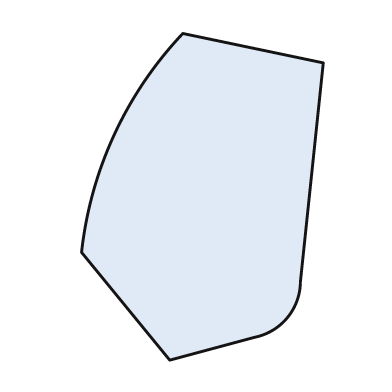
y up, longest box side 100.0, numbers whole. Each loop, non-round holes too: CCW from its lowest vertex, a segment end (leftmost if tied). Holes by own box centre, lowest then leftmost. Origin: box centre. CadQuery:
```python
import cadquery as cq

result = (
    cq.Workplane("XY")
    .moveTo(-10.0, -50.0)
    .lineTo(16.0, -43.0)
    .threePointArc((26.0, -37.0), (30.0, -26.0))
    .lineTo(37.0, 41.0)
    .lineTo(-6.0, 50.0)
    .threePointArc((-27.0, 19.0), (-37.0, -17.0))
    .close()
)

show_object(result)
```